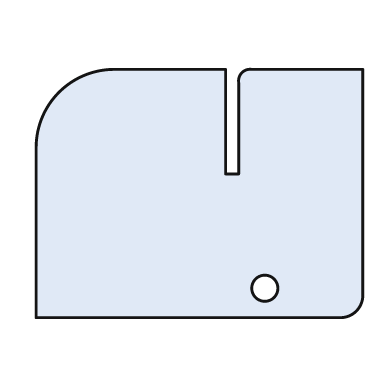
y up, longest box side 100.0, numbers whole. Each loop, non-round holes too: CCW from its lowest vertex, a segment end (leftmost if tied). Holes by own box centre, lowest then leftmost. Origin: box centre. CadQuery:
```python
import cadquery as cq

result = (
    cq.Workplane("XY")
    .moveTo(-50.0, -38.0)
    .lineTo(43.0, -38.0)
    .threePointArc((48.0, -36.0), (50.0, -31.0))
    .lineTo(50.0, 38.0)
    .lineTo(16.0, 38.0)
    .threePointArc((13.0, 37.0), (12.0, 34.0))
    .lineTo(12.0, 6.0)
    .lineTo(8.0, 6.0)
    .lineTo(8.0, 38.0)
    .lineTo(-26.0, 38.0)
    .threePointArc((-43.0, 31.0), (-50.0, 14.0))
    .close()
    .moveTo(20.0, -29.0)
    .circle(4.0)
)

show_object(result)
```